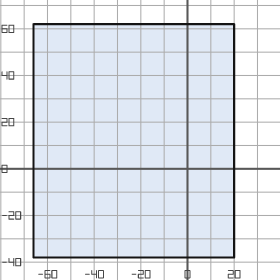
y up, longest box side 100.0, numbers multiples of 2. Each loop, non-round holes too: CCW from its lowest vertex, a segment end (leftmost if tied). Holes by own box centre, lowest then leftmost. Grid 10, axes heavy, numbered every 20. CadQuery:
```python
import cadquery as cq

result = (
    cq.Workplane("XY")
    .moveTo(-66.0, -38.0)
    .lineTo(20.0, -38.0)
    .lineTo(20.0, 62.0)
    .lineTo(-66.0, 62.0)
    .close()
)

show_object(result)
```